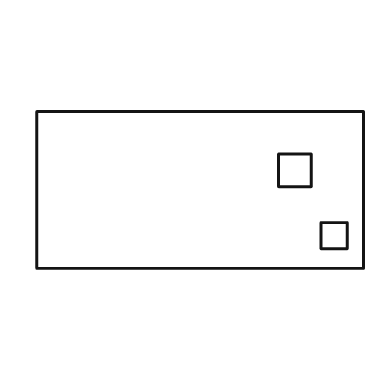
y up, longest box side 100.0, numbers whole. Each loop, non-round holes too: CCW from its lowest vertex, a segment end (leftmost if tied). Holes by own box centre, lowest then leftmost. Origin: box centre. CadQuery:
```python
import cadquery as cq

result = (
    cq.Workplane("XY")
    .moveTo(-50.0, -24.0)
    .lineTo(50.0, -24.0)
    .lineTo(50.0, 24.0)
    .lineTo(-50.0, 24.0)
    .close()
    .moveTo(37.0, -18.0)
    .lineTo(45.0, -18.0)
    .lineTo(45.0, -10.0)
    .lineTo(37.0, -10.0)
    .close()
    .moveTo(24.0, 1.0)
    .lineTo(34.0, 1.0)
    .lineTo(34.0, 11.0)
    .lineTo(24.0, 11.0)
    .close()
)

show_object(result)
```